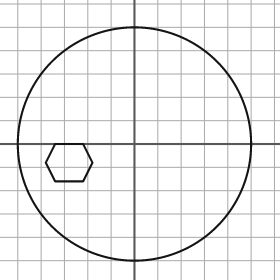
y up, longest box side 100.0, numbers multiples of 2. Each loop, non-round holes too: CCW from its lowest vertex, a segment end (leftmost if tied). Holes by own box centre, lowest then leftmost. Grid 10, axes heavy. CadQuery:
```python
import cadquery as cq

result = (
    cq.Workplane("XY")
    .moveTo(0.0, 0.0)
    .circle(50.0)
    .moveTo(-34.0, -16.0)
    .lineTo(-22.0, -16.0)
    .lineTo(-18.0, -8.0)
    .lineTo(-22.0, 0.0)
    .lineTo(-34.0, 0.0)
    .lineTo(-38.0, -8.0)
    .close()
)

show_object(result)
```